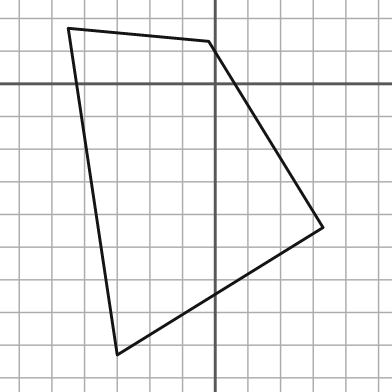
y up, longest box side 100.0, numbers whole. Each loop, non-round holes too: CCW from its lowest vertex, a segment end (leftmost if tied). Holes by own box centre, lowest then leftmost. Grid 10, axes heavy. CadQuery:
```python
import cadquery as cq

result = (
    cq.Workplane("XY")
    .moveTo(-30.0, -83.0)
    .lineTo(33.0, -44.0)
    .lineTo(-2.0, 13.0)
    .lineTo(-45.0, 17.0)
    .close()
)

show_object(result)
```